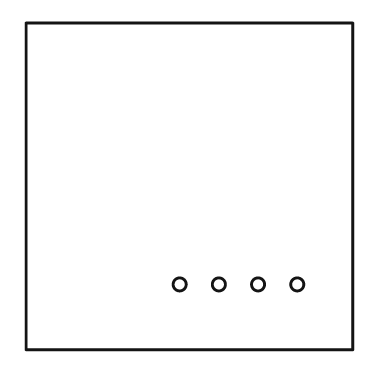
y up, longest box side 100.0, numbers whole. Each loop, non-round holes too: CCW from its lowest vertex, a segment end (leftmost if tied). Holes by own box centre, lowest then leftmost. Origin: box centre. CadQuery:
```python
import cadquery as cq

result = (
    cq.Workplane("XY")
    .moveTo(-50.0, -50.0)
    .lineTo(50.0, -50.0)
    .lineTo(50.0, 50.0)
    .lineTo(-50.0, 50.0)
    .close()
    .moveTo(-3.0, -30.0)
    .circle(2.0)
    .moveTo(9.0, -30.0)
    .circle(2.0)
    .moveTo(21.0, -30.0)
    .circle(2.0)
    .moveTo(33.0, -30.0)
    .circle(2.0)
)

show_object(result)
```